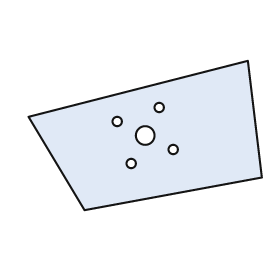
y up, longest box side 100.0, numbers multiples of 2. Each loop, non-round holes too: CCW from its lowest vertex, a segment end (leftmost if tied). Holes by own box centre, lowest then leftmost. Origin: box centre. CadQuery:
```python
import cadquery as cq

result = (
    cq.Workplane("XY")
    .moveTo(-26.0, -32.0)
    .lineTo(50.0, -18.0)
    .lineTo(44.0, 32.0)
    .lineTo(-50.0, 8.0)
    .close()
    .moveTo(-6.0, -12.0)
    .circle(2.0)
    .moveTo(12.0, -6.0)
    .circle(2.0)
    .moveTo(0.0, 0.0)
    .circle(4.0)
    .moveTo(-12.0, 6.0)
    .circle(2.0)
    .moveTo(6.0, 12.0)
    .circle(2.0)
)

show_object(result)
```